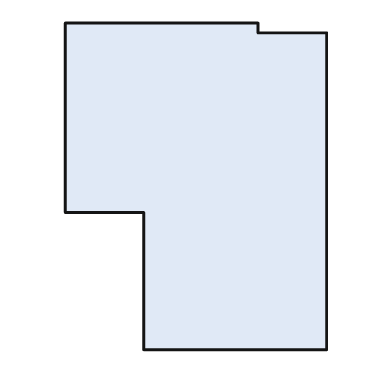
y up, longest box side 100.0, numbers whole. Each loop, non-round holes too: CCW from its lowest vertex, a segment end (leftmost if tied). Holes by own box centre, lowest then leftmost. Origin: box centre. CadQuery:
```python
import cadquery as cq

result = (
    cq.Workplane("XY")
    .moveTo(-16.0, -50.0)
    .lineTo(40.0, -50.0)
    .lineTo(40.0, 47.0)
    .lineTo(19.0, 47.0)
    .lineTo(19.0, 50.0)
    .lineTo(-40.0, 50.0)
    .lineTo(-40.0, -8.0)
    .lineTo(-16.0, -8.0)
    .close()
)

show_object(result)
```